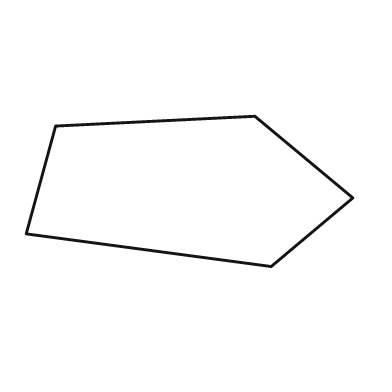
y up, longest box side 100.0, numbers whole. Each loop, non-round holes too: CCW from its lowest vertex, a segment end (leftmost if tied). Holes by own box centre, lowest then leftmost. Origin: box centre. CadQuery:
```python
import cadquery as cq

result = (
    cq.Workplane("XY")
    .moveTo(25.0, -23.0)
    .lineTo(50.0, -2.0)
    .lineTo(20.0, 23.0)
    .lineTo(-41.0, 20.0)
    .lineTo(-50.0, -13.0)
    .close()
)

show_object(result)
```